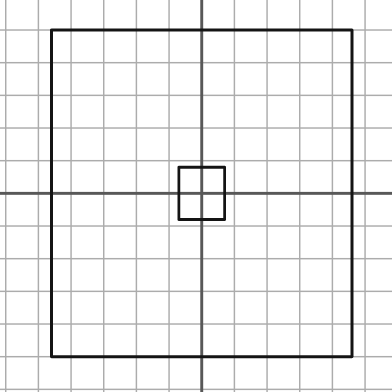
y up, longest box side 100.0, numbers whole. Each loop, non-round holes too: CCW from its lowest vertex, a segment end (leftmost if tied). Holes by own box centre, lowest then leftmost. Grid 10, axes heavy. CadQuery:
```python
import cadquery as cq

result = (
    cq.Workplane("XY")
    .moveTo(-46.0, -50.0)
    .lineTo(46.0, -50.0)
    .lineTo(46.0, 50.0)
    .lineTo(-46.0, 50.0)
    .close()
    .moveTo(-7.0, -8.0)
    .lineTo(7.0, -8.0)
    .lineTo(7.0, 8.0)
    .lineTo(-7.0, 8.0)
    .close()
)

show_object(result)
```